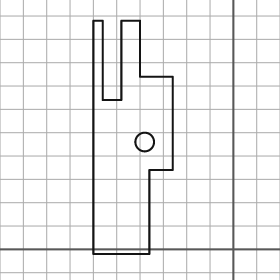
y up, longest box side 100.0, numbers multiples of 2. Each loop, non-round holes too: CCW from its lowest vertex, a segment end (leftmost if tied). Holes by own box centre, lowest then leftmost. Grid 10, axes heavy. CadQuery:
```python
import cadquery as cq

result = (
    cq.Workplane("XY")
    .moveTo(-60.0, -2.0)
    .lineTo(-36.0, -2.0)
    .lineTo(-36.0, 34.0)
    .lineTo(-26.0, 34.0)
    .lineTo(-26.0, 74.0)
    .lineTo(-40.0, 74.0)
    .lineTo(-40.0, 98.0)
    .lineTo(-48.0, 98.0)
    .lineTo(-48.0, 64.0)
    .lineTo(-56.0, 64.0)
    .lineTo(-56.0, 98.0)
    .lineTo(-60.0, 98.0)
    .close()
    .moveTo(-38.0, 46.0)
    .circle(4.0)
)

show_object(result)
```